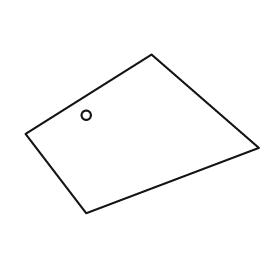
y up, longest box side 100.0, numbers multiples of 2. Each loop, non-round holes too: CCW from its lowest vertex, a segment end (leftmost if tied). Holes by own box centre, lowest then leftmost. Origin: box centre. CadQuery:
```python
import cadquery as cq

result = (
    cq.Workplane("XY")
    .moveTo(-24.0, -34.0)
    .lineTo(50.0, -6.0)
    .lineTo(4.0, 34.0)
    .lineTo(-50.0, 0.0)
    .close()
    .moveTo(-24.0, 8.0)
    .circle(2.0)
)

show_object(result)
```